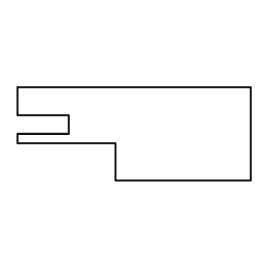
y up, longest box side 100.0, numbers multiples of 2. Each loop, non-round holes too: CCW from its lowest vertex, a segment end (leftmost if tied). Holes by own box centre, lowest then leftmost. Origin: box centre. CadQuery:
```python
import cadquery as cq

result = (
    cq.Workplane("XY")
    .moveTo(-8.0, -20.0)
    .lineTo(50.0, -20.0)
    .lineTo(50.0, 20.0)
    .lineTo(-50.0, 20.0)
    .lineTo(-50.0, 8.0)
    .lineTo(-28.0, 8.0)
    .lineTo(-28.0, 0.0)
    .lineTo(-50.0, 0.0)
    .lineTo(-50.0, -4.0)
    .lineTo(-8.0, -4.0)
    .close()
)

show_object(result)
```